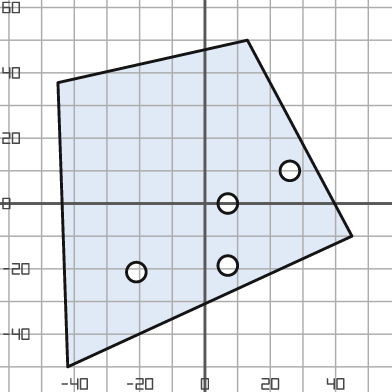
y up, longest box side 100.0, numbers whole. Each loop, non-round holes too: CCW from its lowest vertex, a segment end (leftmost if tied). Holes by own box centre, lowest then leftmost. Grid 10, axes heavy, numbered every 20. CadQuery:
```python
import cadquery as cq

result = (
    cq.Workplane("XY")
    .moveTo(-42.0, -50.0)
    .lineTo(45.0, -10.0)
    .lineTo(13.0, 50.0)
    .lineTo(-45.0, 37.0)
    .close()
    .moveTo(-21.0, -21.0)
    .circle(3.0)
    .moveTo(7.0, -19.0)
    .circle(3.0)
    .moveTo(7.0, 0.0)
    .circle(3.0)
    .moveTo(26.0, 10.0)
    .circle(3.0)
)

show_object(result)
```